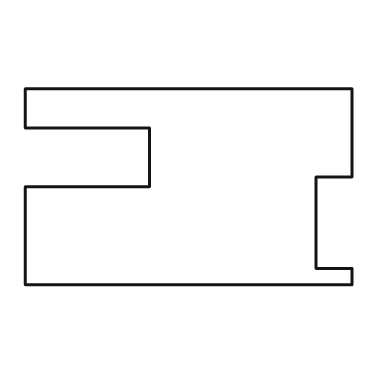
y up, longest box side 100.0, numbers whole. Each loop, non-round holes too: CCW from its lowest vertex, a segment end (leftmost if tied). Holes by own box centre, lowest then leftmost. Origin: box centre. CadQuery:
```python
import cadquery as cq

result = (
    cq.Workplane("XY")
    .moveTo(-50.0, -30.0)
    .lineTo(50.0, -30.0)
    .lineTo(50.0, -25.0)
    .lineTo(39.0, -25.0)
    .lineTo(39.0, 3.0)
    .lineTo(50.0, 3.0)
    .lineTo(50.0, 30.0)
    .lineTo(-50.0, 30.0)
    .lineTo(-50.0, 18.0)
    .lineTo(-12.0, 18.0)
    .lineTo(-12.0, 0.0)
    .lineTo(-50.0, 0.0)
    .close()
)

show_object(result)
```